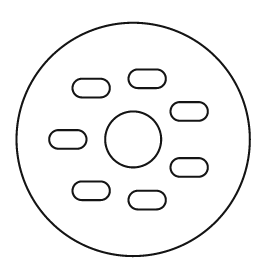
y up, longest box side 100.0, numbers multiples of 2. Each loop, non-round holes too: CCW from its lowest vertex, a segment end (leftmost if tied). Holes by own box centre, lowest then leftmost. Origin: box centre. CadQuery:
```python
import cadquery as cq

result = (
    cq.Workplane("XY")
    .moveTo(0.0, 0.0)
    .circle(50.0)
    .moveTo(2.0, -30.0)
    .lineTo(10.0, -30.0)
    .threePointArc((14.0, -26.0), (10.0, -22.0))
    .lineTo(2.0, -22.0)
    .threePointArc((-2.0, -26.0), (2.0, -30.0))
    .close()
    .moveTo(-22.0, -26.0)
    .lineTo(-14.0, -26.0)
    .threePointArc((-10.0, -22.0), (-14.0, -18.0))
    .lineTo(-22.0, -18.0)
    .threePointArc((-26.0, -22.0), (-22.0, -26.0))
    .close()
    .moveTo(20.0, -16.0)
    .lineTo(28.0, -16.0)
    .threePointArc((32.0, -12.0), (28.0, -8.0))
    .lineTo(20.0, -8.0)
    .threePointArc((16.0, -12.0), (20.0, -16.0))
    .close()
    .moveTo(-32.0, -4.0)
    .lineTo(-24.0, -4.0)
    .threePointArc((-20.0, 0.0), (-24.0, 4.0))
    .lineTo(-32.0, 4.0)
    .threePointArc((-36.0, 0.0), (-32.0, -4.0))
    .close()
    .moveTo(0.0, 0.0)
    .circle(12.0)
    .moveTo(20.0, 8.0)
    .lineTo(28.0, 8.0)
    .threePointArc((32.0, 12.0), (28.0, 16.0))
    .lineTo(20.0, 16.0)
    .threePointArc((16.0, 12.0), (20.0, 8.0))
    .close()
    .moveTo(-22.0, 18.0)
    .lineTo(-14.0, 18.0)
    .threePointArc((-10.0, 22.0), (-14.0, 26.0))
    .lineTo(-22.0, 26.0)
    .threePointArc((-26.0, 22.0), (-22.0, 18.0))
    .close()
    .moveTo(2.0, 22.0)
    .lineTo(10.0, 22.0)
    .threePointArc((14.0, 26.0), (10.0, 30.0))
    .lineTo(2.0, 30.0)
    .threePointArc((-2.0, 26.0), (2.0, 22.0))
    .close()
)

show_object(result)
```